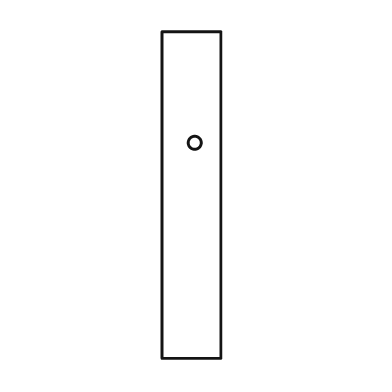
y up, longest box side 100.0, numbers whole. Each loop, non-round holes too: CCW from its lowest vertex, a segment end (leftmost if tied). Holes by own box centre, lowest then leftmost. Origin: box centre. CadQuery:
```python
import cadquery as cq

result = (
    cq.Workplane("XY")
    .moveTo(-9.0, -50.0)
    .lineTo(9.0, -50.0)
    .lineTo(9.0, 50.0)
    .lineTo(-9.0, 50.0)
    .close()
    .moveTo(1.0, 16.0)
    .circle(2.0)
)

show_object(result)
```